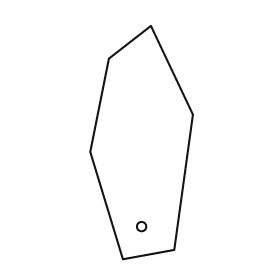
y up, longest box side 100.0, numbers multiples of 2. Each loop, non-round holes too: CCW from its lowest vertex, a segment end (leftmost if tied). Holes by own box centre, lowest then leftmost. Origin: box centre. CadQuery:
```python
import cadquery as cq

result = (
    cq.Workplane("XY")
    .moveTo(-8.0, -50.0)
    .lineTo(14.0, -46.0)
    .lineTo(22.0, 12.0)
    .lineTo(4.0, 50.0)
    .lineTo(-14.0, 36.0)
    .lineTo(-22.0, -4.0)
    .close()
    .moveTo(0.0, -36.0)
    .circle(2.0)
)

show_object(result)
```